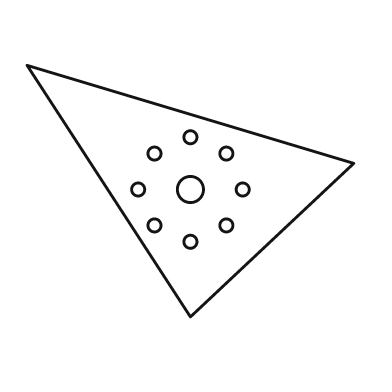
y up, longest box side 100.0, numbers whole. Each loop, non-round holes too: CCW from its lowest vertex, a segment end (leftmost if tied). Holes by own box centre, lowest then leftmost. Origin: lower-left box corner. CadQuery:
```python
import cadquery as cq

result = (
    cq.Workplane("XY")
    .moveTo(50.0, 0.0)
    .lineTo(100.0, 47.0)
    .lineTo(0.0, 77.0)
    .close()
    .moveTo(50.0, 23.0)
    .circle(2.0)
    .moveTo(39.0, 28.0)
    .circle(2.0)
    .moveTo(61.0, 28.0)
    .circle(2.0)
    .moveTo(34.0, 39.0)
    .circle(2.0)
    .moveTo(50.0, 39.0)
    .circle(4.0)
    .moveTo(66.0, 39.0)
    .circle(2.0)
    .moveTo(39.0, 50.0)
    .circle(2.0)
    .moveTo(61.0, 50.0)
    .circle(2.0)
    .moveTo(50.0, 55.0)
    .circle(2.0)
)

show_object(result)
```